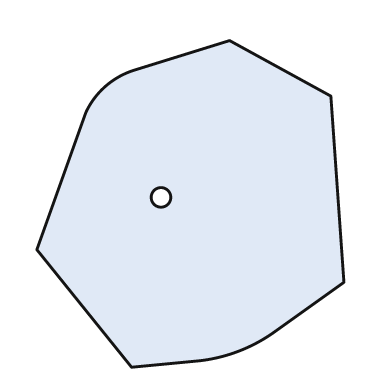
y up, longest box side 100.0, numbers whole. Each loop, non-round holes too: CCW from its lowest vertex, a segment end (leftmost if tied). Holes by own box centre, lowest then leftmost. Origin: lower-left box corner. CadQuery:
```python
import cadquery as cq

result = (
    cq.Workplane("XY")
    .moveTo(29.0, 0.0)
    .lineTo(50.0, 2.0)
    .threePointArc((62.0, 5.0), (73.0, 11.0))
    .lineTo(94.0, 26.0)
    .lineTo(90.0, 83.0)
    .lineTo(59.0, 100.0)
    .lineTo(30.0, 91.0)
    .threePointArc((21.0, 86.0), (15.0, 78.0))
    .lineTo(0.0, 36.0)
    .close()
    .moveTo(38.0, 52.0)
    .circle(3.0)
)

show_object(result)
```